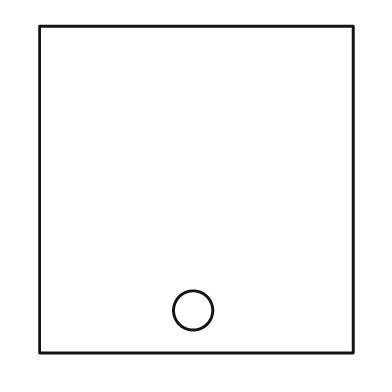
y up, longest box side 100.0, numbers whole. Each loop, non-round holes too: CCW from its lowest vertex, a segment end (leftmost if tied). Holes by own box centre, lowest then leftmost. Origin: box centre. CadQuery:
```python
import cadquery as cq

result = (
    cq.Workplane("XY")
    .moveTo(-48.0, -50.0)
    .lineTo(48.0, -50.0)
    .lineTo(48.0, 50.0)
    .lineTo(-48.0, 50.0)
    .close()
    .moveTo(-1.0, -37.0)
    .circle(6.0)
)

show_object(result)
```